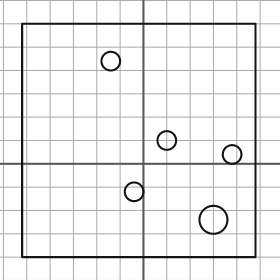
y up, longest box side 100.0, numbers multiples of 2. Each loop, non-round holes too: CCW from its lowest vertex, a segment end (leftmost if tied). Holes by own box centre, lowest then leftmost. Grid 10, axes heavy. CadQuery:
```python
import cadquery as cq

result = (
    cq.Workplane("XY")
    .moveTo(-52.0, -40.0)
    .lineTo(48.0, -40.0)
    .lineTo(48.0, 60.0)
    .lineTo(-52.0, 60.0)
    .close()
    .moveTo(30.0, -24.0)
    .circle(6.0)
    .moveTo(-4.0, -12.0)
    .circle(4.0)
    .moveTo(38.0, 4.0)
    .circle(4.0)
    .moveTo(10.0, 10.0)
    .circle(4.0)
    .moveTo(-14.0, 44.0)
    .circle(4.0)
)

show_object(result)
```